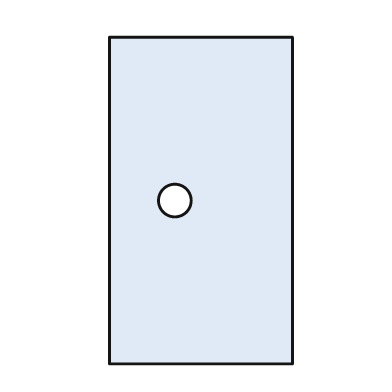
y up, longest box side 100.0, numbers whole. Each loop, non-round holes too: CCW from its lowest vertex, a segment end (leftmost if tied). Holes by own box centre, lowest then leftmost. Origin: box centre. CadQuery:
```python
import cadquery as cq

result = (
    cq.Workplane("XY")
    .moveTo(-28.0, -50.0)
    .lineTo(28.0, -50.0)
    .lineTo(28.0, 50.0)
    .lineTo(-28.0, 50.0)
    .close()
    .moveTo(-8.0, 0.0)
    .circle(5.0)
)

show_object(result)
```